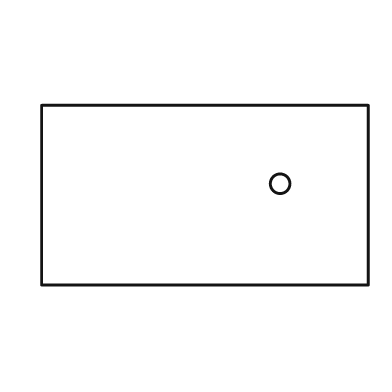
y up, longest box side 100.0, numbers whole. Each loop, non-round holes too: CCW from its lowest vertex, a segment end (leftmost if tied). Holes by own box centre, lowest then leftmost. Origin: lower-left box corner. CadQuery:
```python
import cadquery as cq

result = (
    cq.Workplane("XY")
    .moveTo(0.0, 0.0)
    .lineTo(100.0, 0.0)
    .lineTo(100.0, 55.0)
    .lineTo(0.0, 55.0)
    .close()
    .moveTo(73.0, 31.0)
    .circle(3.0)
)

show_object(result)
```